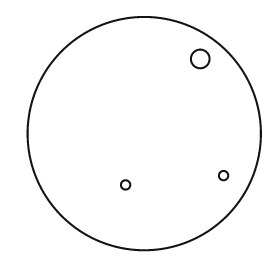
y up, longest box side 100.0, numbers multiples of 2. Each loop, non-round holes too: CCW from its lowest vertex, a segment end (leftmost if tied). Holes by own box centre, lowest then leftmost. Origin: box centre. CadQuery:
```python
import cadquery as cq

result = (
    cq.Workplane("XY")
    .moveTo(0.0, 0.0)
    .circle(50.0)
    .moveTo(-8.0, -22.0)
    .circle(2.0)
    .moveTo(34.0, -18.0)
    .circle(2.0)
    .moveTo(24.0, 32.0)
    .circle(4.0)
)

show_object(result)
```